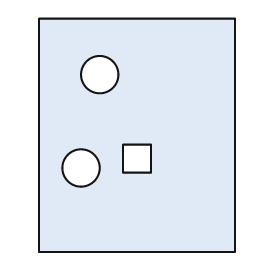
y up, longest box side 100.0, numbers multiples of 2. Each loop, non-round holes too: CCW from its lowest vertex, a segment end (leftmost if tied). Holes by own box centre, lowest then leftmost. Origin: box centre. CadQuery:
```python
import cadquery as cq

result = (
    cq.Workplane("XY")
    .moveTo(-42.0, -50.0)
    .lineTo(42.0, -50.0)
    .lineTo(42.0, 50.0)
    .lineTo(-42.0, 50.0)
    .close()
    .moveTo(-24.0, -14.0)
    .circle(8.0)
    .moveTo(-6.0, -16.0)
    .lineTo(6.0, -16.0)
    .lineTo(6.0, -4.0)
    .lineTo(-6.0, -4.0)
    .close()
    .moveTo(-16.0, 26.0)
    .circle(8.0)
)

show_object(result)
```